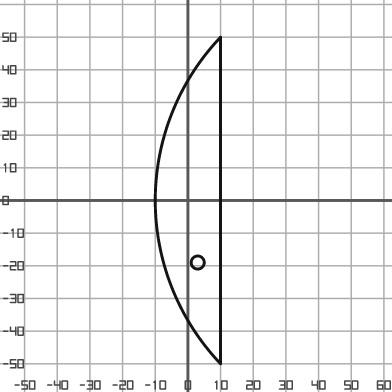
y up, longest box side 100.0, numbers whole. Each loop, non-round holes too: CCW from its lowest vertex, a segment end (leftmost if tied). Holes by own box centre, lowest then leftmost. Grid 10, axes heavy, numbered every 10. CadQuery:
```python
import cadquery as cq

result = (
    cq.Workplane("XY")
    .moveTo(10.0, -50.0)
    .lineTo(10.0, 50.0)
    .threePointArc((-10.0, 0.0), (10.0, -50.0))
    .close()
    .moveTo(3.0, -19.0)
    .circle(2.0)
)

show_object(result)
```